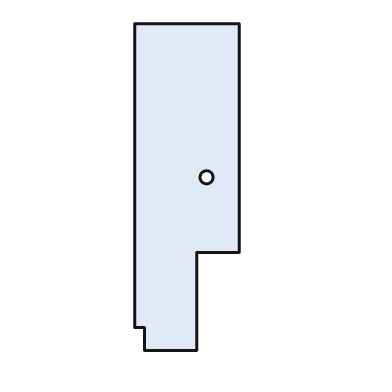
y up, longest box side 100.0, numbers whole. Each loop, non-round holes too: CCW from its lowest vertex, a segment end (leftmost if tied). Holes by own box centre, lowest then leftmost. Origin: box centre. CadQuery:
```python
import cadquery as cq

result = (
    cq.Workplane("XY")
    .moveTo(-13.0, -50.0)
    .lineTo(3.0, -50.0)
    .lineTo(3.0, -20.0)
    .lineTo(16.0, -20.0)
    .lineTo(16.0, 50.0)
    .lineTo(-16.0, 50.0)
    .lineTo(-16.0, -43.0)
    .lineTo(-13.0, -43.0)
    .close()
    .moveTo(6.0, 3.0)
    .circle(2.0)
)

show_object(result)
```